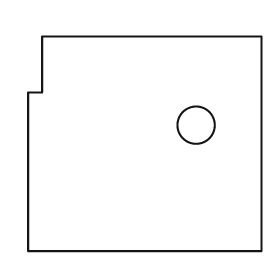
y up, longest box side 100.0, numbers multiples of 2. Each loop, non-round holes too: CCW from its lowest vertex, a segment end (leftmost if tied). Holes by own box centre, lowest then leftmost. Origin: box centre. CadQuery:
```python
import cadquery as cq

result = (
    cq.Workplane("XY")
    .moveTo(-50.0, -46.0)
    .lineTo(50.0, -46.0)
    .lineTo(50.0, 46.0)
    .lineTo(-44.0, 46.0)
    .lineTo(-44.0, 22.0)
    .lineTo(-50.0, 22.0)
    .close()
    .moveTo(22.0, 8.0)
    .circle(8.0)
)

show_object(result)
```